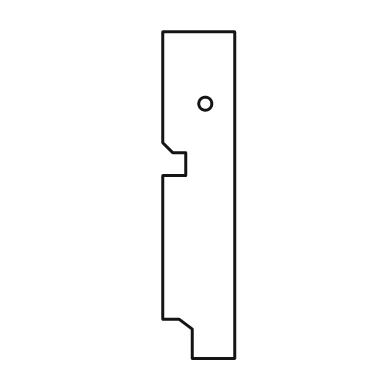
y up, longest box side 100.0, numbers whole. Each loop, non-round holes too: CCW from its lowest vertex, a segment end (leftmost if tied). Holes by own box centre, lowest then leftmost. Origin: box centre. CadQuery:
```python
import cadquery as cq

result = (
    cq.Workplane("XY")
    .moveTo(-2.0, -50.0)
    .lineTo(11.0, -50.0)
    .lineTo(11.0, 50.0)
    .lineTo(-11.0, 50.0)
    .lineTo(-11.0, 16.0)
    .lineTo(-8.0, 13.0)
    .lineTo(-4.0, 13.0)
    .lineTo(-4.0, 6.0)
    .lineTo(-11.0, 6.0)
    .lineTo(-11.0, -38.0)
    .lineTo(-6.0, -38.0)
    .lineTo(-2.0, -41.0)
    .close()
    .moveTo(2.0, 28.0)
    .circle(2.0)
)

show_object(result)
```